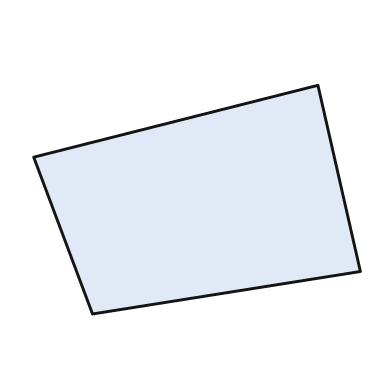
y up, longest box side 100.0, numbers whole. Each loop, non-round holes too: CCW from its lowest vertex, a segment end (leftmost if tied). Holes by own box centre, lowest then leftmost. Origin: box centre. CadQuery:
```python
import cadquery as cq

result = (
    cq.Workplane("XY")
    .moveTo(-32.0, -35.0)
    .lineTo(50.0, -22.0)
    .lineTo(37.0, 35.0)
    .lineTo(-50.0, 13.0)
    .close()
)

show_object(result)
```